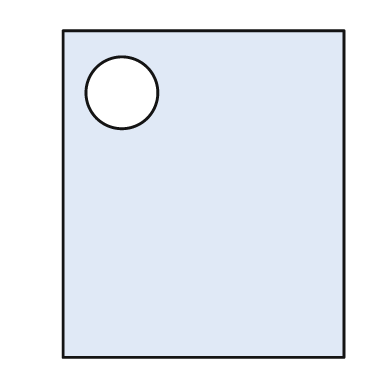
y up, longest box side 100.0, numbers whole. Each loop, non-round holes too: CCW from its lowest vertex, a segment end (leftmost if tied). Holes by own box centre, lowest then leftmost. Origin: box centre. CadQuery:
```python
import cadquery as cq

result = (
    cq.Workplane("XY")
    .moveTo(-43.0, -50.0)
    .lineTo(43.0, -50.0)
    .lineTo(43.0, 50.0)
    .lineTo(-43.0, 50.0)
    .close()
    .moveTo(-25.0, 31.0)
    .circle(11.0)
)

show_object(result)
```